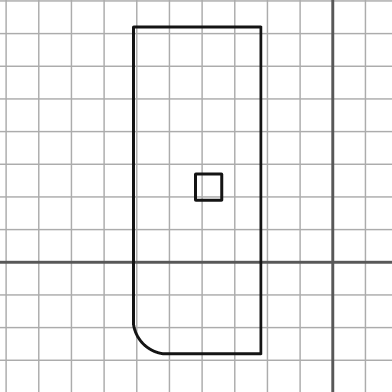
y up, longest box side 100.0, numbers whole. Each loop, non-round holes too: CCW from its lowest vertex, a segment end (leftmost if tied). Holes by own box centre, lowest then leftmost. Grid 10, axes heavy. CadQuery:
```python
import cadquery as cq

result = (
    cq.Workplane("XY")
    .moveTo(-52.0, -28.0)
    .lineTo(-22.0, -28.0)
    .lineTo(-22.0, 72.0)
    .lineTo(-61.0, 72.0)
    .lineTo(-61.0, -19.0)
    .threePointArc((-58.0, -25.0), (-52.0, -28.0))
    .close()
    .moveTo(-42.0, 19.0)
    .lineTo(-34.0, 19.0)
    .lineTo(-34.0, 27.0)
    .lineTo(-42.0, 27.0)
    .close()
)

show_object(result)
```